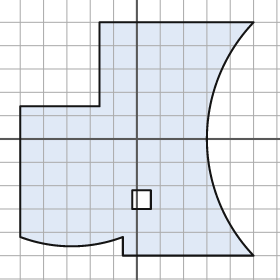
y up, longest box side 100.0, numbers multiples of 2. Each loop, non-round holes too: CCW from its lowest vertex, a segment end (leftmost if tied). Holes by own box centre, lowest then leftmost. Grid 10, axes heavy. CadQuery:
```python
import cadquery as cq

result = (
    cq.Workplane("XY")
    .moveTo(-6.0, -50.0)
    .lineTo(50.0, -50.0)
    .threePointArc((30.0, 0.0), (50.0, 50.0))
    .lineTo(-16.0, 50.0)
    .lineTo(-16.0, 14.0)
    .lineTo(-50.0, 14.0)
    .lineTo(-50.0, -42.0)
    .threePointArc((-28.0, -46.0), (-6.0, -42.0))
    .close()
    .moveTo(-2.0, -30.0)
    .lineTo(6.0, -30.0)
    .lineTo(6.0, -22.0)
    .lineTo(-2.0, -22.0)
    .close()
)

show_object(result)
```